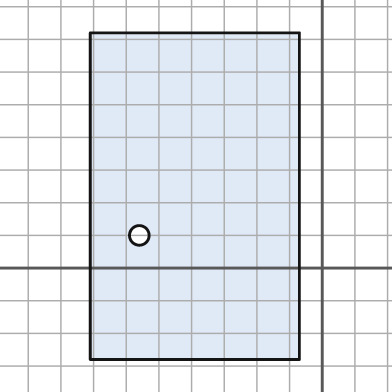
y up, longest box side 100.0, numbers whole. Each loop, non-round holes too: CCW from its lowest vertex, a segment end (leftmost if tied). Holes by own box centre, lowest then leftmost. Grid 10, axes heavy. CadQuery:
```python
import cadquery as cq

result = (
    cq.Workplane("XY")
    .moveTo(-71.0, -28.0)
    .lineTo(-7.0, -28.0)
    .lineTo(-7.0, 72.0)
    .lineTo(-71.0, 72.0)
    .close()
    .moveTo(-56.0, 10.0)
    .circle(3.0)
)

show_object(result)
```